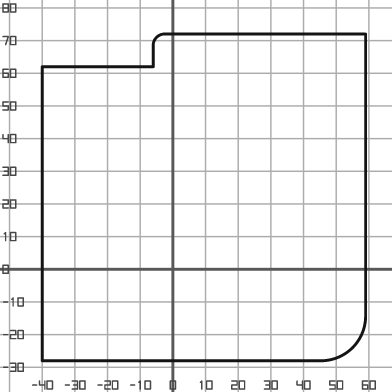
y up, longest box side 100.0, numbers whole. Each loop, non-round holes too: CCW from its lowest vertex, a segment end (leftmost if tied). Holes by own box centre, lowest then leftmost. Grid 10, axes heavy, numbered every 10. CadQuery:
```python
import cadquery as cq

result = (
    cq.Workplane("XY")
    .moveTo(-40.0, -28.0)
    .lineTo(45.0, -28.0)
    .threePointArc((55.0, -24.0), (59.0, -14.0))
    .lineTo(59.0, 72.0)
    .lineTo(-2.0, 72.0)
    .threePointArc((-5.0, 71.0), (-6.0, 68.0))
    .lineTo(-6.0, 62.0)
    .lineTo(-40.0, 62.0)
    .close()
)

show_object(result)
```